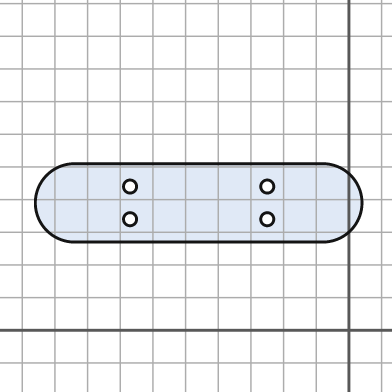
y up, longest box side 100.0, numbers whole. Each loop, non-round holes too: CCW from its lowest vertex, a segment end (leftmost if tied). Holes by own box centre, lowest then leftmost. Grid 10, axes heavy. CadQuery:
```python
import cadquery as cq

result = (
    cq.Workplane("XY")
    .moveTo(-84.0, 27.0)
    .lineTo(-8.0, 27.0)
    .threePointArc((4.0, 39.0), (-8.0, 51.0))
    .lineTo(-84.0, 51.0)
    .threePointArc((-96.0, 39.0), (-84.0, 27.0))
    .close()
    .moveTo(-67.0, 34.0)
    .circle(2.0)
    .moveTo(-25.0, 34.0)
    .circle(2.0)
    .moveTo(-67.0, 44.0)
    .circle(2.0)
    .moveTo(-25.0, 44.0)
    .circle(2.0)
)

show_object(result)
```